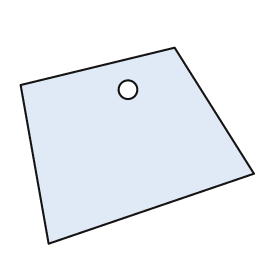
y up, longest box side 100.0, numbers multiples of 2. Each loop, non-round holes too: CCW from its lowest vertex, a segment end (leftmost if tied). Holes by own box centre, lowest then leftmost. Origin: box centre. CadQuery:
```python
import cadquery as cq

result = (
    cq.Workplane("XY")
    .moveTo(-38.0, -42.0)
    .lineTo(50.0, -12.0)
    .lineTo(16.0, 42.0)
    .lineTo(-50.0, 26.0)
    .close()
    .moveTo(-4.0, 24.0)
    .circle(4.0)
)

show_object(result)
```